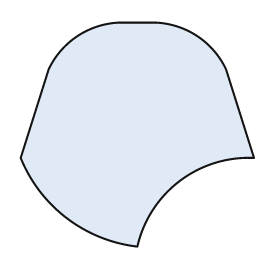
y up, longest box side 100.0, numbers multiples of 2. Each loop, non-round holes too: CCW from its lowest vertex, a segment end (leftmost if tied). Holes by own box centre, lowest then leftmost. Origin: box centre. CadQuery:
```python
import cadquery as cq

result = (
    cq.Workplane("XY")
    .moveTo(0.0, -48.0)
    .threePointArc((18.0, -20.0), (50.0, -10.0))
    .lineTo(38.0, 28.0)
    .threePointArc((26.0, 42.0), (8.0, 48.0))
    .lineTo(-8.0, 48.0)
    .threePointArc((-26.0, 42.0), (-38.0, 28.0))
    .lineTo(-50.0, -10.0)
    .threePointArc((-30.0, -36.0), (0.0, -48.0))
    .close()
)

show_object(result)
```